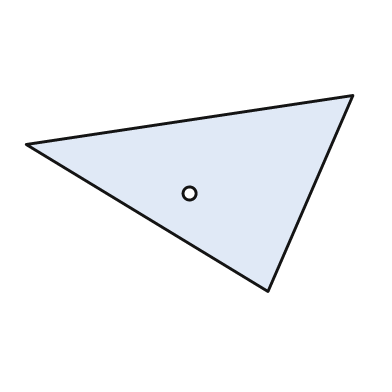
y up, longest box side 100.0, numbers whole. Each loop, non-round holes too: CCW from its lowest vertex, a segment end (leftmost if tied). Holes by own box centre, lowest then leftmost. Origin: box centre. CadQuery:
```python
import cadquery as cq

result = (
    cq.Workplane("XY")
    .moveTo(24.0, -30.0)
    .lineTo(50.0, 30.0)
    .lineTo(-50.0, 15.0)
    .close()
    .moveTo(0.0, 0.0)
    .circle(2.0)
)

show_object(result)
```